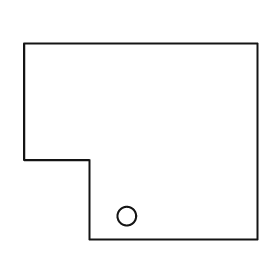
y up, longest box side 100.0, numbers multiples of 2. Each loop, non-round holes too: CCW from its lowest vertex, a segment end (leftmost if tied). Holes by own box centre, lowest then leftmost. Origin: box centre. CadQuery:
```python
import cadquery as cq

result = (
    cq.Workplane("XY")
    .moveTo(-22.0, -42.0)
    .lineTo(50.0, -42.0)
    .lineTo(50.0, 42.0)
    .lineTo(-50.0, 42.0)
    .lineTo(-50.0, -8.0)
    .lineTo(-22.0, -8.0)
    .close()
    .moveTo(-6.0, -32.0)
    .circle(4.0)
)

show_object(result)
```